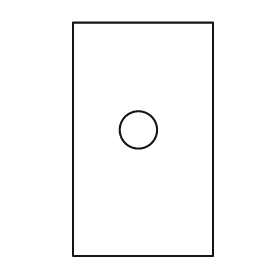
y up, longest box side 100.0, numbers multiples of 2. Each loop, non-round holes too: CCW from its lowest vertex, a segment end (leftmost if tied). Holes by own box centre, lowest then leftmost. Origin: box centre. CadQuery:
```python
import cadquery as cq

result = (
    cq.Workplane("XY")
    .moveTo(-30.0, -50.0)
    .lineTo(30.0, -50.0)
    .lineTo(30.0, 50.0)
    .lineTo(-30.0, 50.0)
    .close()
    .moveTo(-2.0, 4.0)
    .circle(8.0)
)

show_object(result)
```